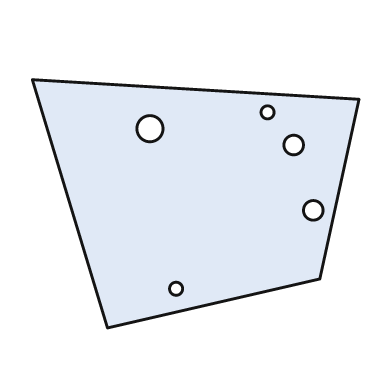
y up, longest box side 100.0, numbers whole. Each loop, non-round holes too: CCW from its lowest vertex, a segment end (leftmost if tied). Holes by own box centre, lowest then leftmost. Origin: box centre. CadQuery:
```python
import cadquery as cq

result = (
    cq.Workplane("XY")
    .moveTo(-27.0, -38.0)
    .lineTo(38.0, -23.0)
    .lineTo(50.0, 32.0)
    .lineTo(-50.0, 38.0)
    .close()
    .moveTo(-6.0, -26.0)
    .circle(2.0)
    .moveTo(36.0, -2.0)
    .circle(3.0)
    .moveTo(30.0, 18.0)
    .circle(3.0)
    .moveTo(-14.0, 23.0)
    .circle(4.0)
    .moveTo(22.0, 28.0)
    .circle(2.0)
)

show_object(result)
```